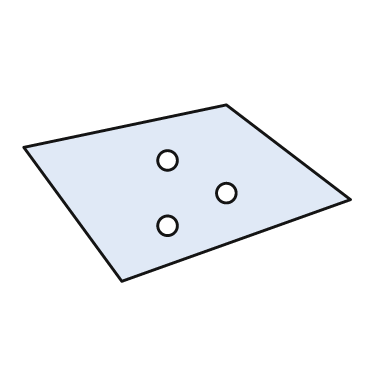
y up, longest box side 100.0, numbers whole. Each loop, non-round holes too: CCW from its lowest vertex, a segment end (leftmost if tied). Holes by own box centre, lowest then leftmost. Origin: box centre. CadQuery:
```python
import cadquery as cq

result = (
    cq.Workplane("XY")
    .moveTo(-20.0, -27.0)
    .lineTo(50.0, -2.0)
    .lineTo(12.0, 27.0)
    .lineTo(-50.0, 14.0)
    .close()
    .moveTo(-6.0, -10.0)
    .circle(3.0)
    .moveTo(12.0, 0.0)
    .circle(3.0)
    .moveTo(-6.0, 10.0)
    .circle(3.0)
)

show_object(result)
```